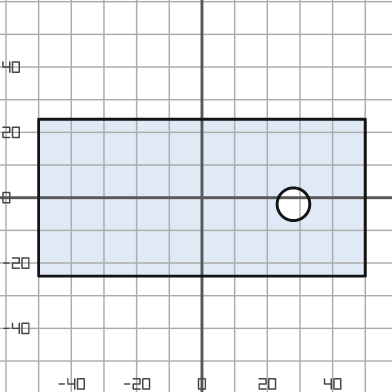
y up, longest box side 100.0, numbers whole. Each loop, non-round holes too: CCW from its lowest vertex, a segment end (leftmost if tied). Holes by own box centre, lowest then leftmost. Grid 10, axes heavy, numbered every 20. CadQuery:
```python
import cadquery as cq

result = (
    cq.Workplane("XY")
    .moveTo(-50.0, -24.0)
    .lineTo(50.0, -24.0)
    .lineTo(50.0, 24.0)
    .lineTo(-50.0, 24.0)
    .close()
    .moveTo(28.0, -2.0)
    .circle(5.0)
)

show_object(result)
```